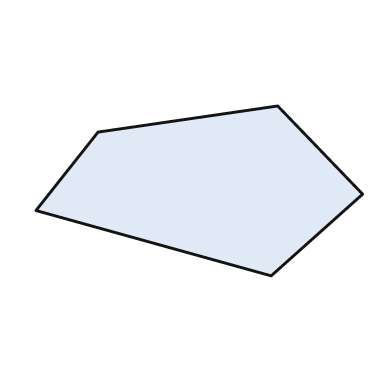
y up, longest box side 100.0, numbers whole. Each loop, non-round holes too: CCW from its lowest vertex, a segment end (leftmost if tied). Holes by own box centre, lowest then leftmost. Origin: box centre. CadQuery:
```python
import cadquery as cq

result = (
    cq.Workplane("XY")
    .moveTo(22.0, -26.0)
    .lineTo(50.0, -1.0)
    .lineTo(24.0, 26.0)
    .lineTo(-31.0, 18.0)
    .lineTo(-50.0, -6.0)
    .close()
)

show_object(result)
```